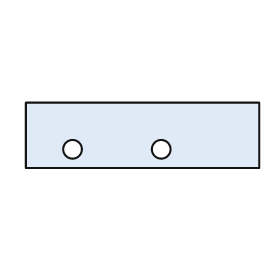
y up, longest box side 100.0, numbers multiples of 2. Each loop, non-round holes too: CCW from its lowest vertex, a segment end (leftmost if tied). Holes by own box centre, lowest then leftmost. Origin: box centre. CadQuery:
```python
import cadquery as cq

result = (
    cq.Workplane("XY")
    .moveTo(-50.0, -14.0)
    .lineTo(50.0, -14.0)
    .lineTo(50.0, 14.0)
    .lineTo(-50.0, 14.0)
    .close()
    .moveTo(-30.0, -6.0)
    .circle(4.0)
    .moveTo(8.0, -6.0)
    .circle(4.0)
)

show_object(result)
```